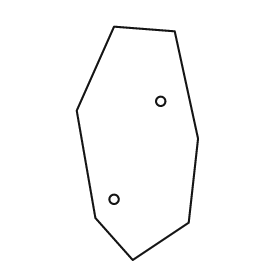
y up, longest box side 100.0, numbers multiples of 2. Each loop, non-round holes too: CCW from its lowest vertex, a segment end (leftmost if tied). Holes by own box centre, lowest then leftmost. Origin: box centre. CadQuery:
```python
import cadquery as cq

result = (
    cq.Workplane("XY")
    .moveTo(-2.0, -50.0)
    .lineTo(22.0, -34.0)
    .lineTo(26.0, 2.0)
    .lineTo(16.0, 48.0)
    .lineTo(-10.0, 50.0)
    .lineTo(-26.0, 14.0)
    .lineTo(-18.0, -32.0)
    .close()
    .moveTo(-10.0, -24.0)
    .circle(2.0)
    .moveTo(10.0, 18.0)
    .circle(2.0)
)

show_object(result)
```